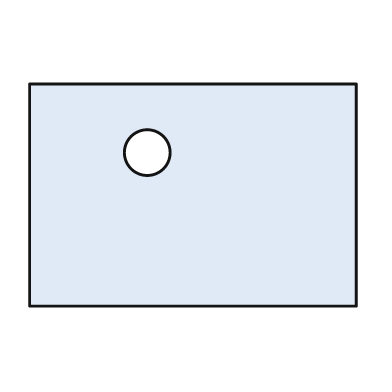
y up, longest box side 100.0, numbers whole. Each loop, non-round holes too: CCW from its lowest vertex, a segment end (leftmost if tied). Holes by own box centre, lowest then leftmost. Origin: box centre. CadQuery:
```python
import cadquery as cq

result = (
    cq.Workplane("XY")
    .moveTo(-50.0, -34.0)
    .lineTo(50.0, -34.0)
    .lineTo(50.0, 34.0)
    .lineTo(-50.0, 34.0)
    .close()
    .moveTo(-14.0, 13.0)
    .circle(7.0)
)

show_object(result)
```